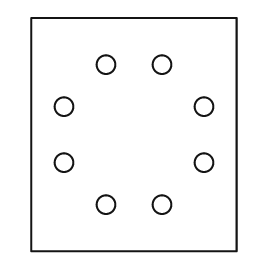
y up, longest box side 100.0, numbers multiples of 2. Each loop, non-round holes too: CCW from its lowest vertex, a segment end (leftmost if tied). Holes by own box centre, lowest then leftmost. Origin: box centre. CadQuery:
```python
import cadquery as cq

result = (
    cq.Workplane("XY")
    .moveTo(-44.0, -50.0)
    .lineTo(44.0, -50.0)
    .lineTo(44.0, 50.0)
    .lineTo(-44.0, 50.0)
    .close()
    .moveTo(-12.0, -30.0)
    .circle(4.0)
    .moveTo(12.0, -30.0)
    .circle(4.0)
    .moveTo(-30.0, -12.0)
    .circle(4.0)
    .moveTo(30.0, -12.0)
    .circle(4.0)
    .moveTo(-30.0, 12.0)
    .circle(4.0)
    .moveTo(30.0, 12.0)
    .circle(4.0)
    .moveTo(-12.0, 30.0)
    .circle(4.0)
    .moveTo(12.0, 30.0)
    .circle(4.0)
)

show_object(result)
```